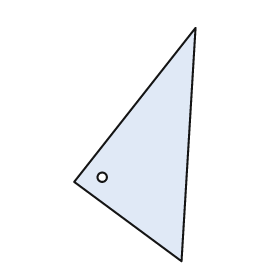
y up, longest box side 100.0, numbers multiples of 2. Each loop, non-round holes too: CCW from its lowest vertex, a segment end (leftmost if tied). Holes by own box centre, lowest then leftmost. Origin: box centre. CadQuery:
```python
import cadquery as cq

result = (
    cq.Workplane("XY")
    .moveTo(20.0, -50.0)
    .lineTo(26.0, 50.0)
    .lineTo(-26.0, -16.0)
    .close()
    .moveTo(-14.0, -14.0)
    .circle(2.0)
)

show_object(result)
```